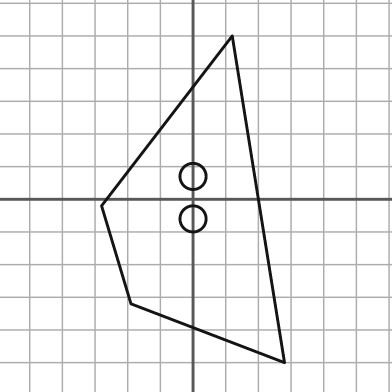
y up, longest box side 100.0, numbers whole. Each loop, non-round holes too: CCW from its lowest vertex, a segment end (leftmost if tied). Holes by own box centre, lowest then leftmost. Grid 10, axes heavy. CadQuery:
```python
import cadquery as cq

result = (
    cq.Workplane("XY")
    .moveTo(28.0, -50.0)
    .lineTo(12.0, 50.0)
    .lineTo(-28.0, -2.0)
    .lineTo(-19.0, -32.0)
    .close()
    .moveTo(0.0, -6.0)
    .circle(4.0)
    .moveTo(0.0, 7.0)
    .circle(4.0)
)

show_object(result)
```